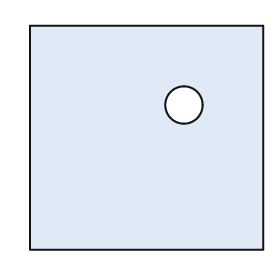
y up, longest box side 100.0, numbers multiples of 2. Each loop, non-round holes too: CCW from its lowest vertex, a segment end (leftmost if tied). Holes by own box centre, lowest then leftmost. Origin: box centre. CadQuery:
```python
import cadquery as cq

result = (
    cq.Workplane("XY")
    .moveTo(-50.0, -48.0)
    .lineTo(50.0, -48.0)
    .lineTo(50.0, 48.0)
    .lineTo(-50.0, 48.0)
    .close()
    .moveTo(16.0, 14.0)
    .circle(8.0)
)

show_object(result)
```